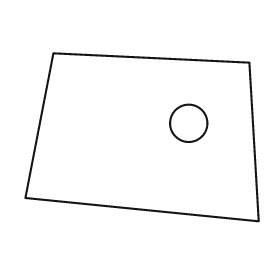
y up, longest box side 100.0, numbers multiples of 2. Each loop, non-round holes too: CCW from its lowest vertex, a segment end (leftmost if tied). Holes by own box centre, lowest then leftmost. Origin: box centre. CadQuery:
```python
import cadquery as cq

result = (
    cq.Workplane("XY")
    .moveTo(50.0, -36.0)
    .lineTo(46.0, 32.0)
    .lineTo(-38.0, 36.0)
    .lineTo(-50.0, -26.0)
    .close()
    .moveTo(20.0, 6.0)
    .circle(8.0)
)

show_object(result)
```